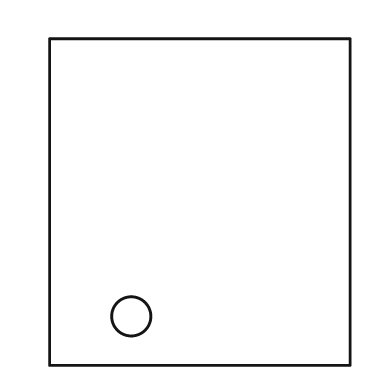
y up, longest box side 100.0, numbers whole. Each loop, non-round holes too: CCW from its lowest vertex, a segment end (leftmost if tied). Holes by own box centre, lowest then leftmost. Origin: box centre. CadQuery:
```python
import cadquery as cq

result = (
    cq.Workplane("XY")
    .moveTo(-46.0, -50.0)
    .lineTo(46.0, -50.0)
    .lineTo(46.0, 50.0)
    .lineTo(-46.0, 50.0)
    .close()
    .moveTo(-21.0, -35.0)
    .circle(6.0)
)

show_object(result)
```